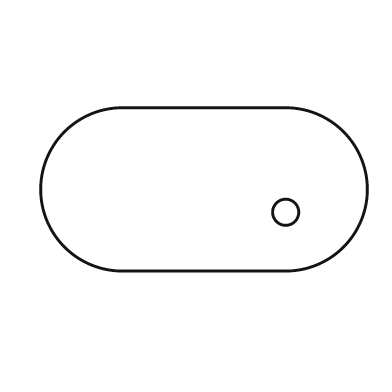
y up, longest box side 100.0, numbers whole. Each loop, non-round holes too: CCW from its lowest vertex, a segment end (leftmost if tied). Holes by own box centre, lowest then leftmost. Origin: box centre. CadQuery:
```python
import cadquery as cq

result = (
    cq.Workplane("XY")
    .moveTo(-25.0, -25.0)
    .lineTo(25.0, -25.0)
    .threePointArc((50.0, 0.0), (25.0, 25.0))
    .lineTo(-25.0, 25.0)
    .threePointArc((-50.0, 0.0), (-25.0, -25.0))
    .close()
    .moveTo(25.0, -7.0)
    .circle(4.0)
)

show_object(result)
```